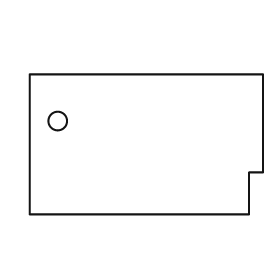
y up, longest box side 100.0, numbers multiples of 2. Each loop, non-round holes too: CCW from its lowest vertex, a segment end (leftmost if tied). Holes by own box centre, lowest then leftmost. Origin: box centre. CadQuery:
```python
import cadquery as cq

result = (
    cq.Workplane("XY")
    .moveTo(-50.0, -30.0)
    .lineTo(44.0, -30.0)
    .lineTo(44.0, -12.0)
    .lineTo(50.0, -12.0)
    .lineTo(50.0, 30.0)
    .lineTo(-50.0, 30.0)
    .close()
    .moveTo(-38.0, 10.0)
    .circle(4.0)
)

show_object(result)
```